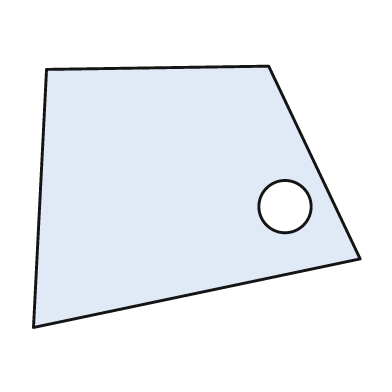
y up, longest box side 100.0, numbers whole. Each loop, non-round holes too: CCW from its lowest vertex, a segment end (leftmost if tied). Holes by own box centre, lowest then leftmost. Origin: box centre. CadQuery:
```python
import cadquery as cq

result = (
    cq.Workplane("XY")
    .moveTo(-50.0, -40.0)
    .lineTo(50.0, -19.0)
    .lineTo(22.0, 40.0)
    .lineTo(-46.0, 39.0)
    .close()
    .moveTo(27.0, -3.0)
    .circle(8.0)
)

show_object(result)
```